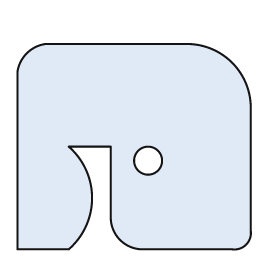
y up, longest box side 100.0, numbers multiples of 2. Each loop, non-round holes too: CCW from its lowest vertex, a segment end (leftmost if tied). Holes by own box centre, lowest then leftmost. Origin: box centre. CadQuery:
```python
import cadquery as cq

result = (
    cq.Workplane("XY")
    .moveTo(-50.0, -44.0)
    .lineTo(-28.0, -44.0)
    .threePointArc((-18.0, -22.0), (-28.0, 0.0))
    .lineTo(-10.0, 0.0)
    .lineTo(-10.0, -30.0)
    .threePointArc((-6.0, -40.0), (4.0, -44.0))
    .lineTo(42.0, -44.0)
    .threePointArc((48.0, -42.0), (50.0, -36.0))
    .lineTo(50.0, 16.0)
    .threePointArc((42.0, 36.0), (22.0, 44.0))
    .lineTo(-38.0, 44.0)
    .threePointArc((-46.0, 40.0), (-50.0, 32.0))
    .close()
    .moveTo(6.0, -6.0)
    .circle(6.0)
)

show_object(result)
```